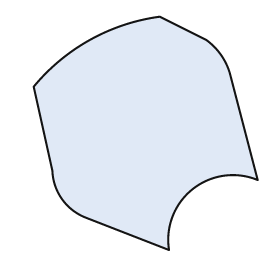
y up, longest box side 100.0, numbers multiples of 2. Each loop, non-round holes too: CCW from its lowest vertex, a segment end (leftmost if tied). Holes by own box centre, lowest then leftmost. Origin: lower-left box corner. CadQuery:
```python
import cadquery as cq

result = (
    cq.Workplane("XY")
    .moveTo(58.0, 0.0)
    .threePointArc((68.0, 26.0), (96.0, 30.0))
    .lineTo(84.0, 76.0)
    .threePointArc((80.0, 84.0), (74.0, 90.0))
    .lineTo(54.0, 100.0)
    .threePointArc((24.0, 90.0), (0.0, 70.0))
    .lineTo(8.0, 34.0)
    .threePointArc((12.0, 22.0), (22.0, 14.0))
    .close()
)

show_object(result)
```